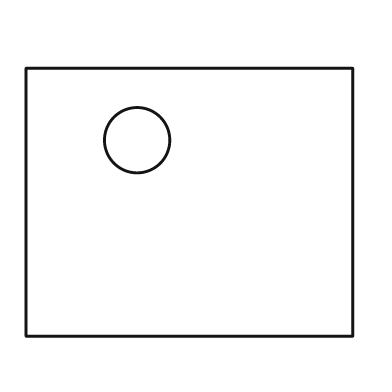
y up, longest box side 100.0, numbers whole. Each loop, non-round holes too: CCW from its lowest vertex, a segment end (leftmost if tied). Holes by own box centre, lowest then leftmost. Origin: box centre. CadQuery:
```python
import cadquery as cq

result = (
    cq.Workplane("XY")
    .moveTo(-50.0, -41.0)
    .lineTo(50.0, -41.0)
    .lineTo(50.0, 41.0)
    .lineTo(-50.0, 41.0)
    .close()
    .moveTo(-16.0, 19.0)
    .circle(10.0)
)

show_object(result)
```